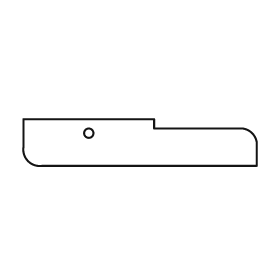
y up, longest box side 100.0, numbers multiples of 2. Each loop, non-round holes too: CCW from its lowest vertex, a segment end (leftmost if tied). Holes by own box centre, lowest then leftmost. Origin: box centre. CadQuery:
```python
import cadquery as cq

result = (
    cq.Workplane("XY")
    .moveTo(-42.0, -10.0)
    .lineTo(50.0, -10.0)
    .lineTo(50.0, 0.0)
    .threePointArc((48.0, 4.0), (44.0, 6.0))
    .lineTo(6.0, 6.0)
    .lineTo(6.0, 10.0)
    .lineTo(-50.0, 10.0)
    .lineTo(-50.0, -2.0)
    .threePointArc((-48.0, -8.0), (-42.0, -10.0))
    .close()
    .moveTo(-22.0, 4.0)
    .circle(2.0)
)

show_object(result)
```